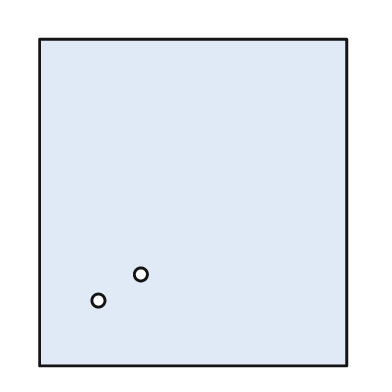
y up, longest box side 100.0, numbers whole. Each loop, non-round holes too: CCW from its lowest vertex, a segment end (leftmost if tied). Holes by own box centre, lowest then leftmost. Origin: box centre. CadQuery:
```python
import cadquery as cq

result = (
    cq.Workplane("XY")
    .moveTo(-47.0, -50.0)
    .lineTo(47.0, -50.0)
    .lineTo(47.0, 50.0)
    .lineTo(-47.0, 50.0)
    .close()
    .moveTo(-29.0, -30.0)
    .circle(2.0)
    .moveTo(-16.0, -22.0)
    .circle(2.0)
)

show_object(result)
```